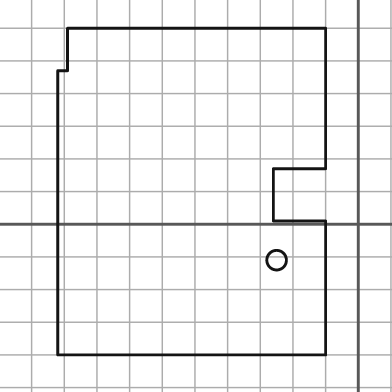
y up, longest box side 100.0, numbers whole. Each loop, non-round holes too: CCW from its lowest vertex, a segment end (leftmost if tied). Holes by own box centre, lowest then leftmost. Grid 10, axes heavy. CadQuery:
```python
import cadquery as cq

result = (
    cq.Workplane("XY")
    .moveTo(-92.0, -40.0)
    .lineTo(-10.0, -40.0)
    .lineTo(-10.0, 1.0)
    .lineTo(-26.0, 1.0)
    .lineTo(-26.0, 17.0)
    .lineTo(-10.0, 17.0)
    .lineTo(-10.0, 60.0)
    .lineTo(-89.0, 60.0)
    .lineTo(-89.0, 47.0)
    .lineTo(-92.0, 47.0)
    .close()
    .moveTo(-25.0, -11.0)
    .circle(3.0)
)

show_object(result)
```